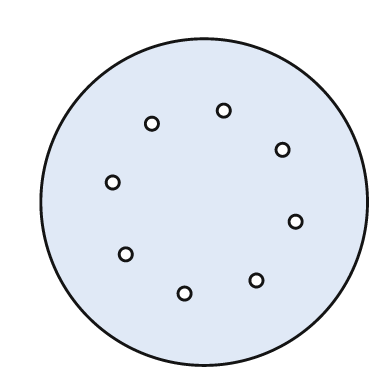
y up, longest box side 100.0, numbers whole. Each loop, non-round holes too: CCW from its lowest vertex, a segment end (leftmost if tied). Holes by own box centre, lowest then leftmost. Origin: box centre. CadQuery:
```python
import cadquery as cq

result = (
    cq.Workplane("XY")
    .moveTo(0.0, 0.0)
    .circle(50.0)
    .moveTo(-6.0, -28.0)
    .circle(2.0)
    .moveTo(16.0, -24.0)
    .circle(2.0)
    .moveTo(-24.0, -16.0)
    .circle(2.0)
    .moveTo(28.0, -6.0)
    .circle(2.0)
    .moveTo(-28.0, 6.0)
    .circle(2.0)
    .moveTo(24.0, 16.0)
    .circle(2.0)
    .moveTo(-16.0, 24.0)
    .circle(2.0)
    .moveTo(6.0, 28.0)
    .circle(2.0)
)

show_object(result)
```